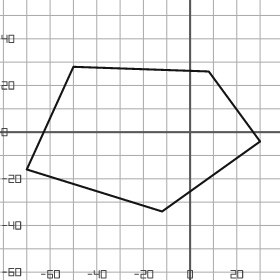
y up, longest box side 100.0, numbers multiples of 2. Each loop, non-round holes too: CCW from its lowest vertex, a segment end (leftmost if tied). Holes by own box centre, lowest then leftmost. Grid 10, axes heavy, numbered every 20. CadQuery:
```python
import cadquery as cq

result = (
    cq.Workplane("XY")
    .moveTo(-12.0, -34.0)
    .lineTo(30.0, -4.0)
    .lineTo(8.0, 26.0)
    .lineTo(-50.0, 28.0)
    .lineTo(-70.0, -16.0)
    .close()
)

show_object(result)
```